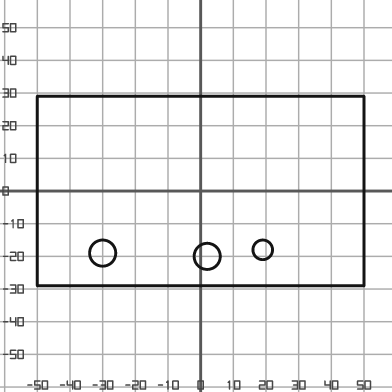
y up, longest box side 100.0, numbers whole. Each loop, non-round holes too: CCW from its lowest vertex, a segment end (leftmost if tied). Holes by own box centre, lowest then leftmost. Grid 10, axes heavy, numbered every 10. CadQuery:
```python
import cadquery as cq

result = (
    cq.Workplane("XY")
    .moveTo(-50.0, -29.0)
    .lineTo(50.0, -29.0)
    .lineTo(50.0, 29.0)
    .lineTo(-50.0, 29.0)
    .close()
    .moveTo(2.0, -20.0)
    .circle(4.0)
    .moveTo(-30.0, -19.0)
    .circle(4.0)
    .moveTo(19.0, -18.0)
    .circle(3.0)
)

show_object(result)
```